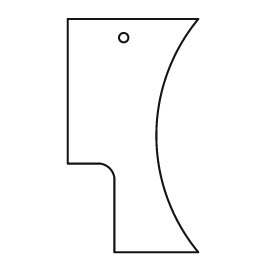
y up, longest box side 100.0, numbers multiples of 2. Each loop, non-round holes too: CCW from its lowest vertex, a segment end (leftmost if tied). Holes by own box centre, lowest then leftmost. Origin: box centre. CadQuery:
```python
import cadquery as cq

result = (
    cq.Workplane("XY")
    .moveTo(-8.0, -50.0)
    .lineTo(28.0, -50.0)
    .threePointArc((10.0, 0.0), (28.0, 50.0))
    .lineTo(-28.0, 50.0)
    .lineTo(-28.0, -12.0)
    .lineTo(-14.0, -12.0)
    .threePointArc((-10.0, -14.0), (-8.0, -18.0))
    .close()
    .moveTo(-4.0, 42.0)
    .circle(2.0)
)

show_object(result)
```